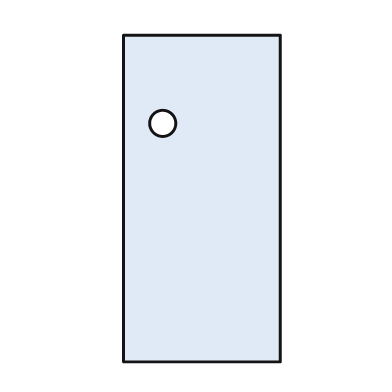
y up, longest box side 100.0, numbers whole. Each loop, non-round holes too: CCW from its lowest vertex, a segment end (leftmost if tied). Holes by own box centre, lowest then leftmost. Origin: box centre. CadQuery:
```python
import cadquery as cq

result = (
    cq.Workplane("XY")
    .moveTo(-24.0, -50.0)
    .lineTo(24.0, -50.0)
    .lineTo(24.0, 50.0)
    .lineTo(-24.0, 50.0)
    .close()
    .moveTo(-12.0, 23.0)
    .circle(4.0)
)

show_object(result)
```